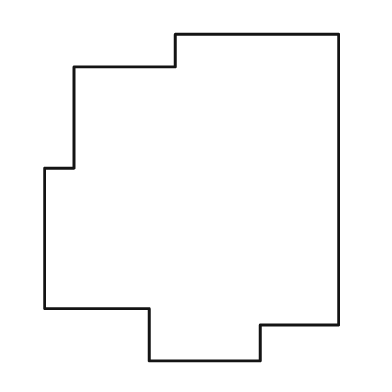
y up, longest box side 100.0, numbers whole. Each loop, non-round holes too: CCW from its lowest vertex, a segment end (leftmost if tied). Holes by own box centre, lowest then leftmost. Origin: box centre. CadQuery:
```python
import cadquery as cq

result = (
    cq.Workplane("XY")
    .moveTo(-13.0, -50.0)
    .lineTo(21.0, -50.0)
    .lineTo(21.0, -39.0)
    .lineTo(45.0, -39.0)
    .lineTo(45.0, 50.0)
    .lineTo(-5.0, 50.0)
    .lineTo(-5.0, 40.0)
    .lineTo(-36.0, 40.0)
    .lineTo(-36.0, 9.0)
    .lineTo(-45.0, 9.0)
    .lineTo(-45.0, -34.0)
    .lineTo(-13.0, -34.0)
    .close()
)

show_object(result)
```